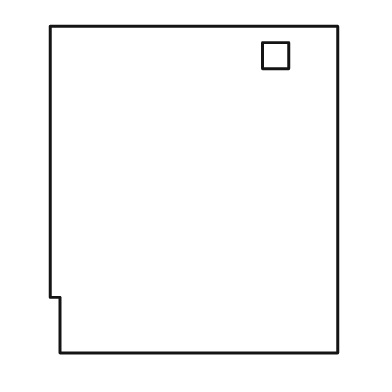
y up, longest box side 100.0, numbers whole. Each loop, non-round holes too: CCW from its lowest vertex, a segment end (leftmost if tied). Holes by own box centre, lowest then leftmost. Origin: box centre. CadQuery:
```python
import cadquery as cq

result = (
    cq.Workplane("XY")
    .moveTo(-41.0, -50.0)
    .lineTo(44.0, -50.0)
    .lineTo(44.0, 50.0)
    .lineTo(-44.0, 50.0)
    .lineTo(-44.0, -33.0)
    .lineTo(-41.0, -33.0)
    .close()
    .moveTo(21.0, 37.0)
    .lineTo(29.0, 37.0)
    .lineTo(29.0, 45.0)
    .lineTo(21.0, 45.0)
    .close()
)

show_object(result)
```